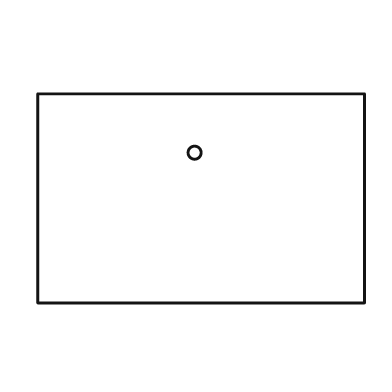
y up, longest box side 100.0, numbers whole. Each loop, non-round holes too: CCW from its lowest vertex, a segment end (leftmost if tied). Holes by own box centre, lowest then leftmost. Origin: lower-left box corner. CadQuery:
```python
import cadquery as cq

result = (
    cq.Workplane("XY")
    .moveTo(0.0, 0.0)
    .lineTo(100.0, 0.0)
    .lineTo(100.0, 64.0)
    .lineTo(0.0, 64.0)
    .close()
    .moveTo(48.0, 46.0)
    .circle(2.0)
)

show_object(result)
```